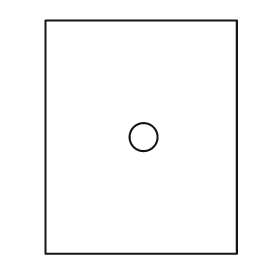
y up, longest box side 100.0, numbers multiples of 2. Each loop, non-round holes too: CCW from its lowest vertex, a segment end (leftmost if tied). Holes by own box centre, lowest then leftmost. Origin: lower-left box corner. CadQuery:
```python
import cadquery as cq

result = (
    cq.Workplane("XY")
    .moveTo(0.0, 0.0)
    .lineTo(82.0, 0.0)
    .lineTo(82.0, 100.0)
    .lineTo(0.0, 100.0)
    .close()
    .moveTo(42.0, 50.0)
    .circle(6.0)
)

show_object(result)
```